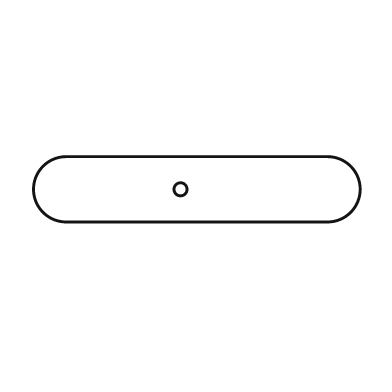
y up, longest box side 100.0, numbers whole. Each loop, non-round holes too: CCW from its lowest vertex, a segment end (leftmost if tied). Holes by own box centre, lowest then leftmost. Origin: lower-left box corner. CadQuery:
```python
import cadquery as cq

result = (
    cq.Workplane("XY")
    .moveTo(10.0, 0.0)
    .lineTo(90.0, 0.0)
    .threePointArc((100.0, 10.0), (90.0, 20.0))
    .lineTo(10.0, 20.0)
    .threePointArc((0.0, 10.0), (10.0, 0.0))
    .close()
    .moveTo(45.0, 10.0)
    .circle(2.0)
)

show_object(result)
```